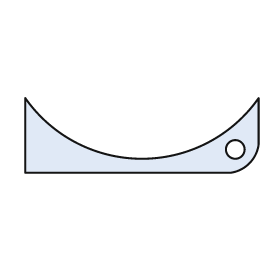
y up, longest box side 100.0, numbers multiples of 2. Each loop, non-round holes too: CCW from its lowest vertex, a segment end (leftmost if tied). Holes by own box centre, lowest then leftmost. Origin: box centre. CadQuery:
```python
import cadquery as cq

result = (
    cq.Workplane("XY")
    .moveTo(-50.0, -16.0)
    .lineTo(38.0, -16.0)
    .threePointArc((46.0, -12.0), (50.0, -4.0))
    .lineTo(50.0, 16.0)
    .threePointArc((0.0, -10.0), (-50.0, 16.0))
    .close()
    .moveTo(40.0, -6.0)
    .circle(4.0)
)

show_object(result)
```